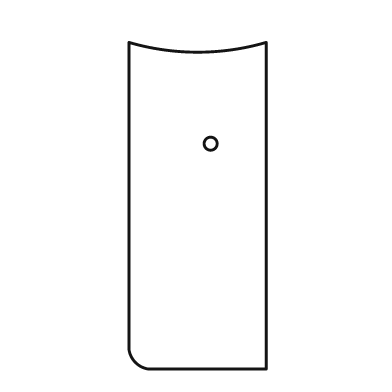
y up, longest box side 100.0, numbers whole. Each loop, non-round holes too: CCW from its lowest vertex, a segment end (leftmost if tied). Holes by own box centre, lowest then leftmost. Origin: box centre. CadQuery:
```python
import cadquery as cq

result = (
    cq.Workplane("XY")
    .moveTo(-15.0, -50.0)
    .lineTo(21.0, -50.0)
    .lineTo(21.0, 50.0)
    .threePointArc((0.0, 47.0), (-21.0, 50.0))
    .lineTo(-21.0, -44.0)
    .threePointArc((-19.0, -48.0), (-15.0, -50.0))
    .close()
    .moveTo(4.0, 19.0)
    .circle(2.0)
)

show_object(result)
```